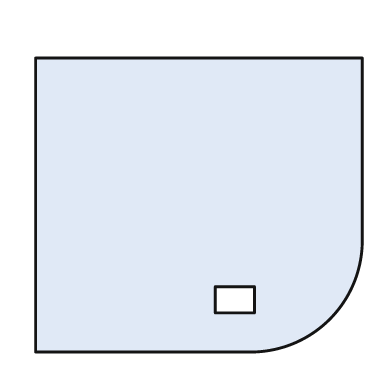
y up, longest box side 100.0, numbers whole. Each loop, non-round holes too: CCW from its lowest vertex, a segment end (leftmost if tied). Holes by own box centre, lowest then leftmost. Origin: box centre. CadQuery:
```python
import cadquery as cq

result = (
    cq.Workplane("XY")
    .moveTo(-50.0, -45.0)
    .lineTo(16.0, -45.0)
    .threePointArc((40.0, -35.0), (50.0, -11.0))
    .lineTo(50.0, 45.0)
    .lineTo(-50.0, 45.0)
    .close()
    .moveTo(5.0, -33.0)
    .lineTo(17.0, -33.0)
    .lineTo(17.0, -25.0)
    .lineTo(5.0, -25.0)
    .close()
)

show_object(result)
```